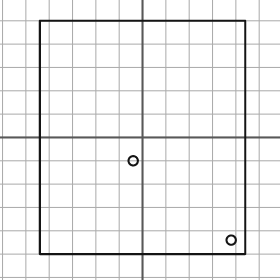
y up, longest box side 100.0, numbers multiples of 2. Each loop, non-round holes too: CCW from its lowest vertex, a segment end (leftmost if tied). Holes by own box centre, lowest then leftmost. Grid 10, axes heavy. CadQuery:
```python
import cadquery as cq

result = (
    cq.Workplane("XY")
    .moveTo(-44.0, -50.0)
    .lineTo(44.0, -50.0)
    .lineTo(44.0, 50.0)
    .lineTo(-44.0, 50.0)
    .close()
    .moveTo(38.0, -44.0)
    .circle(2.0)
    .moveTo(-4.0, -10.0)
    .circle(2.0)
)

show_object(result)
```